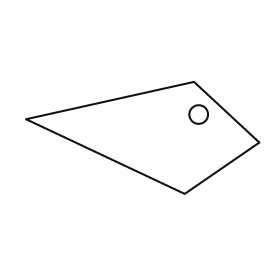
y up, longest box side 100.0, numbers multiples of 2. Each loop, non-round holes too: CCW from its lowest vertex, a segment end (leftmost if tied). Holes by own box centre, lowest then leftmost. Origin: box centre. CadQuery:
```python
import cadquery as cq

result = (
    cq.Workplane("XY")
    .moveTo(18.0, -24.0)
    .lineTo(50.0, -2.0)
    .lineTo(22.0, 24.0)
    .lineTo(-50.0, 8.0)
    .close()
    .moveTo(24.0, 10.0)
    .circle(4.0)
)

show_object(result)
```